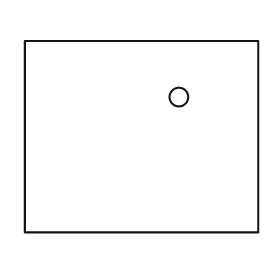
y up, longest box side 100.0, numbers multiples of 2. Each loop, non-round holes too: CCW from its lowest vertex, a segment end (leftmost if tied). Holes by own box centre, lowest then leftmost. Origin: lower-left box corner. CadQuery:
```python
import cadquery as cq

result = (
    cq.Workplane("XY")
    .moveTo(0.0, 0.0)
    .lineTo(100.0, 0.0)
    .lineTo(100.0, 82.0)
    .lineTo(0.0, 82.0)
    .close()
    .moveTo(66.0, 58.0)
    .circle(4.0)
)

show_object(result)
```